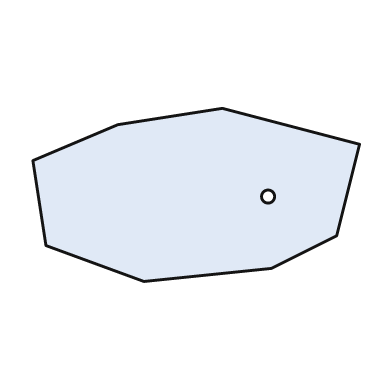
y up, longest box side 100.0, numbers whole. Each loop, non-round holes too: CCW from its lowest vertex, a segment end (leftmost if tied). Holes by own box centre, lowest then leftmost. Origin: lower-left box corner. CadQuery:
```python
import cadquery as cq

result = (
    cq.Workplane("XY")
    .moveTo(34.0, 0.0)
    .lineTo(73.0, 4.0)
    .lineTo(93.0, 14.0)
    .lineTo(100.0, 42.0)
    .lineTo(58.0, 53.0)
    .lineTo(26.0, 48.0)
    .lineTo(0.0, 37.0)
    .lineTo(4.0, 11.0)
    .close()
    .moveTo(72.0, 26.0)
    .circle(2.0)
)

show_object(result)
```